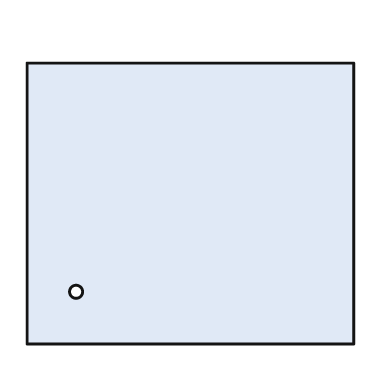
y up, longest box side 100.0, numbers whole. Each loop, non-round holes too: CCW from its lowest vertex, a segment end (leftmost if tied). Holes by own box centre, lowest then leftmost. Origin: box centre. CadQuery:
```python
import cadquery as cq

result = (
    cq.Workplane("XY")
    .moveTo(-50.0, -43.0)
    .lineTo(50.0, -43.0)
    .lineTo(50.0, 43.0)
    .lineTo(-50.0, 43.0)
    .close()
    .moveTo(-35.0, -27.0)
    .circle(2.0)
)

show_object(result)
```